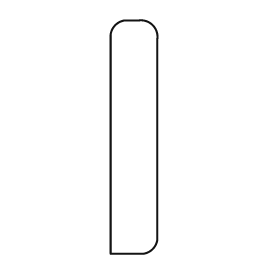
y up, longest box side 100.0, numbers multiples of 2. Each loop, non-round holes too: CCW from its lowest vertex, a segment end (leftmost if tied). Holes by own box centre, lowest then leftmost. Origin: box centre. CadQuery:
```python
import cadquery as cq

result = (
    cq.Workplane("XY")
    .moveTo(-10.0, -50.0)
    .lineTo(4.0, -50.0)
    .threePointArc((8.0, -48.0), (10.0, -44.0))
    .lineTo(10.0, 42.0)
    .threePointArc((8.0, 48.0), (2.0, 50.0))
    .lineTo(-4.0, 50.0)
    .threePointArc((-8.0, 48.0), (-10.0, 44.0))
    .close()
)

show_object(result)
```